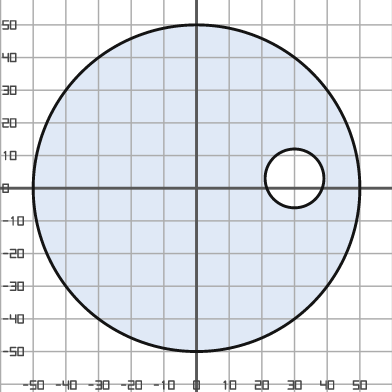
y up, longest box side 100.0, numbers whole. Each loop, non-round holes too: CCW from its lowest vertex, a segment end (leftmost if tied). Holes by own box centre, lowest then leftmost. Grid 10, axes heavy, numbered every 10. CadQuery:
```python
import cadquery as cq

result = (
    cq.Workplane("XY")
    .moveTo(0.0, 0.0)
    .circle(50.0)
    .moveTo(30.0, 3.0)
    .circle(9.0)
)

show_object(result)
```